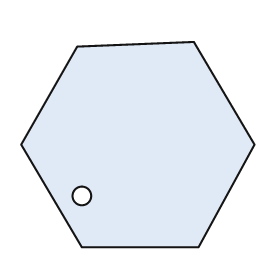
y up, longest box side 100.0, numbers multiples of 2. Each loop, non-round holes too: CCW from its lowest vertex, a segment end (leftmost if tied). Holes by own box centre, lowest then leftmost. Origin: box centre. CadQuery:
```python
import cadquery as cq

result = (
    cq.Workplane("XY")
    .moveTo(-24.0, -44.0)
    .lineTo(26.0, -44.0)
    .lineTo(50.0, 0.0)
    .lineTo(24.0, 44.0)
    .lineTo(-26.0, 42.0)
    .lineTo(-50.0, 0.0)
    .close()
    .moveTo(-24.0, -22.0)
    .circle(4.0)
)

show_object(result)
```